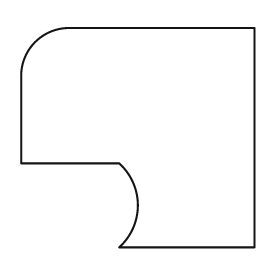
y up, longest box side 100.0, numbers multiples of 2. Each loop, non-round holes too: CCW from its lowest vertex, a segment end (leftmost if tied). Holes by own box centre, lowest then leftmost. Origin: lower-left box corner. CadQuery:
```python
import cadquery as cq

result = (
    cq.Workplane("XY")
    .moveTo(42.0, 0.0)
    .lineTo(100.0, 0.0)
    .lineTo(100.0, 94.0)
    .lineTo(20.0, 94.0)
    .threePointArc((6.0, 88.0), (0.0, 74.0))
    .lineTo(0.0, 36.0)
    .lineTo(42.0, 36.0)
    .threePointArc((50.0, 18.0), (42.0, 0.0))
    .close()
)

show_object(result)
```